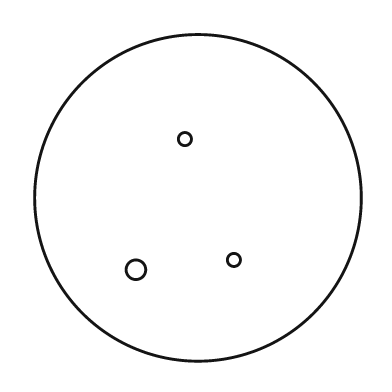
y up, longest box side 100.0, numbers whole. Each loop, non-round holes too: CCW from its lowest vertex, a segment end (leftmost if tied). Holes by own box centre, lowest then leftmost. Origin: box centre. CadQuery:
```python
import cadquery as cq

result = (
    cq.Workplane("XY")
    .moveTo(0.0, 0.0)
    .circle(50.0)
    .moveTo(-19.0, -22.0)
    .circle(3.0)
    .moveTo(11.0, -19.0)
    .circle(2.0)
    .moveTo(-4.0, 18.0)
    .circle(2.0)
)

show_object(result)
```